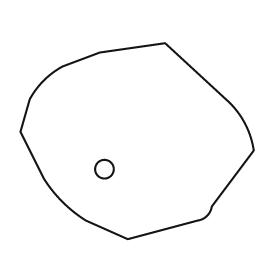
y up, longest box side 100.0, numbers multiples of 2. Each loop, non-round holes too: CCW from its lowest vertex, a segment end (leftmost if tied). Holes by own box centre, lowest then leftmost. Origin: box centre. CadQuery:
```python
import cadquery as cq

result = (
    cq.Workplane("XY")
    .moveTo(-4.0, -42.0)
    .lineTo(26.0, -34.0)
    .threePointArc((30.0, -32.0), (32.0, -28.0))
    .lineTo(50.0, -4.0)
    .threePointArc((46.0, 8.0), (38.0, 18.0))
    .lineTo(12.0, 42.0)
    .lineTo(-16.0, 38.0)
    .lineTo(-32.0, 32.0)
    .threePointArc((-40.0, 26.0), (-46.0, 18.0))
    .lineTo(-50.0, 4.0)
    .lineTo(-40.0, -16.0)
    .threePointArc((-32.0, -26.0), (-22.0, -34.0))
    .close()
    .moveTo(-14.0, -12.0)
    .circle(4.0)
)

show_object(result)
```